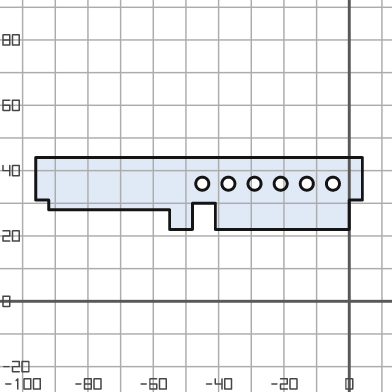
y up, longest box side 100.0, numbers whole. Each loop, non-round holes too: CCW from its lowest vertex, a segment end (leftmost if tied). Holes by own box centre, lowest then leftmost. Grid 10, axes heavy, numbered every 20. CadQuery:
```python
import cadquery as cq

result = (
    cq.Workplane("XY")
    .moveTo(-55.0, 22.0)
    .lineTo(-48.0, 22.0)
    .lineTo(-48.0, 30.0)
    .lineTo(-41.0, 30.0)
    .lineTo(-41.0, 22.0)
    .lineTo(0.0, 22.0)
    .lineTo(0.0, 31.0)
    .lineTo(4.0, 31.0)
    .lineTo(4.0, 44.0)
    .lineTo(-96.0, 44.0)
    .lineTo(-96.0, 31.0)
    .lineTo(-92.0, 31.0)
    .lineTo(-92.0, 28.0)
    .lineTo(-55.0, 28.0)
    .close()
    .moveTo(-45.0, 36.0)
    .circle(2.0)
    .moveTo(-37.0, 36.0)
    .circle(2.0)
    .moveTo(-29.0, 36.0)
    .circle(2.0)
    .moveTo(-21.0, 36.0)
    .circle(2.0)
    .moveTo(-13.0, 36.0)
    .circle(2.0)
    .moveTo(-5.0, 36.0)
    .circle(2.0)
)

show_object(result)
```